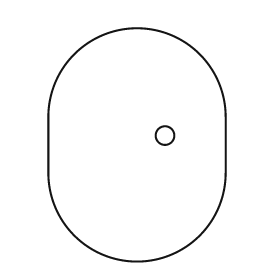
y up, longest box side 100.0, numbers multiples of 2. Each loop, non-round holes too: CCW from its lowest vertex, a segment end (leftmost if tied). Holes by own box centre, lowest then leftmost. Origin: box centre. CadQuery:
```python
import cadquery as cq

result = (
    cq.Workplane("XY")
    .moveTo(-38.0, -12.0)
    .threePointArc((0.0, -50.0), (38.0, -12.0))
    .lineTo(38.0, 12.0)
    .threePointArc((0.0, 50.0), (-38.0, 12.0))
    .close()
    .moveTo(12.0, 4.0)
    .circle(4.0)
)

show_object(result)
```